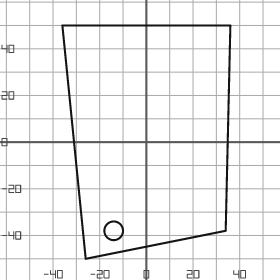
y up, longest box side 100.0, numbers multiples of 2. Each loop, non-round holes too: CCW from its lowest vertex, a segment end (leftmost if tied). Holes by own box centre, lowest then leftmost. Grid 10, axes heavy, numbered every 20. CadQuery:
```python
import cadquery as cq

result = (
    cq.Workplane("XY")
    .moveTo(-26.0, -50.0)
    .lineTo(34.0, -38.0)
    .lineTo(36.0, 50.0)
    .lineTo(-36.0, 50.0)
    .close()
    .moveTo(-14.0, -38.0)
    .circle(4.0)
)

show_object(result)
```